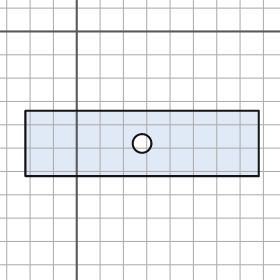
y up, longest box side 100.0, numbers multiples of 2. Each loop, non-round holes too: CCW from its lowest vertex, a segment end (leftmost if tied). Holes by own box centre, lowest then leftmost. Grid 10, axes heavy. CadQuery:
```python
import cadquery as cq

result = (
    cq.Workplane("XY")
    .moveTo(-22.0, -62.0)
    .lineTo(78.0, -62.0)
    .lineTo(78.0, -34.0)
    .lineTo(-22.0, -34.0)
    .close()
    .moveTo(28.0, -48.0)
    .circle(4.0)
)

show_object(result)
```